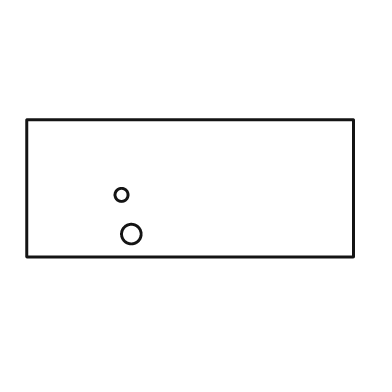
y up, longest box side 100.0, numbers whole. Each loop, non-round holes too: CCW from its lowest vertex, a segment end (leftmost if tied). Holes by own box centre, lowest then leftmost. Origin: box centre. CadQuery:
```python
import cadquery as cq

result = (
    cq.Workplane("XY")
    .moveTo(-50.0, -21.0)
    .lineTo(50.0, -21.0)
    .lineTo(50.0, 21.0)
    .lineTo(-50.0, 21.0)
    .close()
    .moveTo(-18.0, -14.0)
    .circle(3.0)
    .moveTo(-21.0, -2.0)
    .circle(2.0)
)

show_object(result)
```